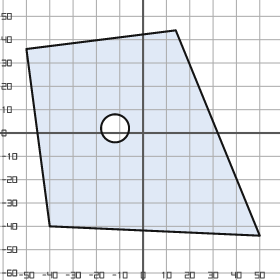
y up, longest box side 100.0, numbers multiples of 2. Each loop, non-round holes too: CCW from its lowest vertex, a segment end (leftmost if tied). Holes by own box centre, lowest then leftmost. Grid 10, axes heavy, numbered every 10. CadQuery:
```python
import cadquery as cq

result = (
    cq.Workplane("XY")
    .moveTo(50.0, -44.0)
    .lineTo(14.0, 44.0)
    .lineTo(-50.0, 36.0)
    .lineTo(-40.0, -40.0)
    .close()
    .moveTo(-12.0, 2.0)
    .circle(6.0)
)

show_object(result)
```